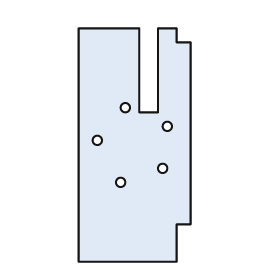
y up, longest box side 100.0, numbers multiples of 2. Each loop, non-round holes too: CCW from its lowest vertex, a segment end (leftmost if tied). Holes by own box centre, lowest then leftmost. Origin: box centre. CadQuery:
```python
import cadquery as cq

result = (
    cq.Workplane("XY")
    .moveTo(-24.0, -50.0)
    .lineTo(18.0, -50.0)
    .lineTo(18.0, -34.0)
    .lineTo(24.0, -34.0)
    .lineTo(24.0, 44.0)
    .lineTo(18.0, 44.0)
    .lineTo(18.0, 50.0)
    .lineTo(10.0, 50.0)
    .lineTo(10.0, 14.0)
    .lineTo(2.0, 14.0)
    .lineTo(2.0, 50.0)
    .lineTo(-24.0, 50.0)
    .close()
    .moveTo(-6.0, -16.0)
    .circle(2.0)
    .moveTo(12.0, -10.0)
    .circle(2.0)
    .moveTo(-16.0, 2.0)
    .circle(2.0)
    .moveTo(14.0, 8.0)
    .circle(2.0)
    .moveTo(-4.0, 16.0)
    .circle(2.0)
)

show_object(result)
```